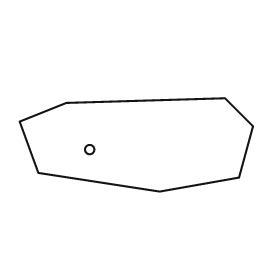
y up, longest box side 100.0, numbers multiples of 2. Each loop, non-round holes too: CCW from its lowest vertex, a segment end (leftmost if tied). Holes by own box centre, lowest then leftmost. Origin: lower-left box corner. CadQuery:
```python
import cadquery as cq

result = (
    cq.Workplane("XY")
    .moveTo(60.0, 0.0)
    .lineTo(94.0, 6.0)
    .lineTo(100.0, 28.0)
    .lineTo(88.0, 40.0)
    .lineTo(20.0, 38.0)
    .lineTo(0.0, 30.0)
    .lineTo(8.0, 8.0)
    .close()
    .moveTo(30.0, 18.0)
    .circle(2.0)
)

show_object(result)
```